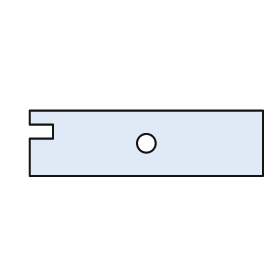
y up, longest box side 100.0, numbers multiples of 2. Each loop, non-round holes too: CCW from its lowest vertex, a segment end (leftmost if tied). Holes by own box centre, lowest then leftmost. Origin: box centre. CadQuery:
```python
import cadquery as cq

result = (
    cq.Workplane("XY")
    .moveTo(-50.0, -14.0)
    .lineTo(50.0, -14.0)
    .lineTo(50.0, 14.0)
    .lineTo(-50.0, 14.0)
    .lineTo(-50.0, 8.0)
    .lineTo(-40.0, 8.0)
    .lineTo(-40.0, 2.0)
    .lineTo(-50.0, 2.0)
    .close()
    .moveTo(0.0, 0.0)
    .circle(4.0)
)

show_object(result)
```